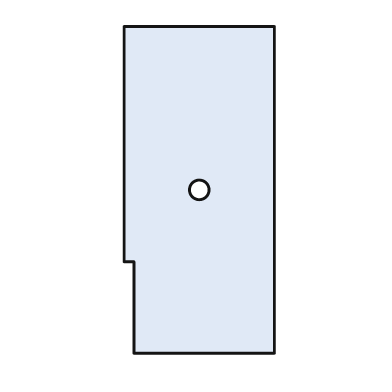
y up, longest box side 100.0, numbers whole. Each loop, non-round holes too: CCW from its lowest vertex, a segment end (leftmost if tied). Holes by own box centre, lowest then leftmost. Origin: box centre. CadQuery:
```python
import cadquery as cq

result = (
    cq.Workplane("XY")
    .moveTo(-20.0, -50.0)
    .lineTo(23.0, -50.0)
    .lineTo(23.0, 50.0)
    .lineTo(-23.0, 50.0)
    .lineTo(-23.0, -22.0)
    .lineTo(-20.0, -22.0)
    .close()
    .moveTo(0.0, 0.0)
    .circle(3.0)
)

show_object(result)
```